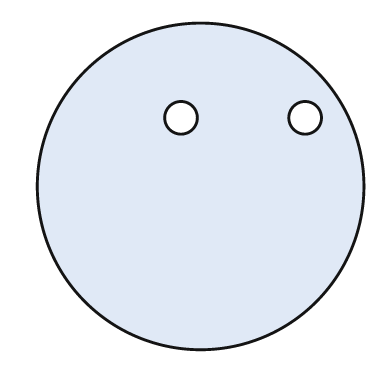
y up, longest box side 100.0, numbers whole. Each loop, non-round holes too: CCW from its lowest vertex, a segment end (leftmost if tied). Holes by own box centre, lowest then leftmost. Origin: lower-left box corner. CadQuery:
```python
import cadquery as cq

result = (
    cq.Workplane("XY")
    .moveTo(50.0, 50.0)
    .circle(50.0)
    .moveTo(44.0, 71.0)
    .circle(5.0)
    .moveTo(82.0, 71.0)
    .circle(5.0)
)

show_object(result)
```